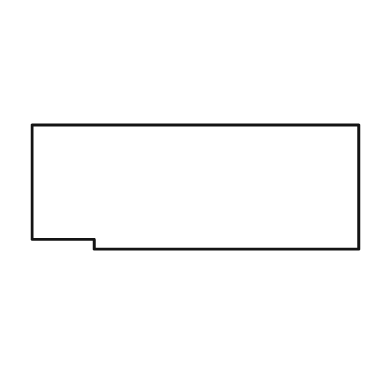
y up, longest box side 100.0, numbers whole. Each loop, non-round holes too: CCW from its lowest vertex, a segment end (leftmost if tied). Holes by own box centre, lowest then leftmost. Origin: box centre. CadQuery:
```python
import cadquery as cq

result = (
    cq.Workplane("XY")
    .moveTo(-31.0, -19.0)
    .lineTo(50.0, -19.0)
    .lineTo(50.0, 19.0)
    .lineTo(-50.0, 19.0)
    .lineTo(-50.0, -16.0)
    .lineTo(-31.0, -16.0)
    .close()
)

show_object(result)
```